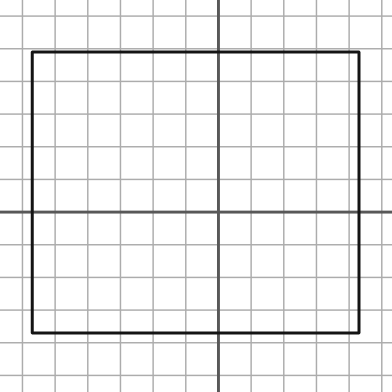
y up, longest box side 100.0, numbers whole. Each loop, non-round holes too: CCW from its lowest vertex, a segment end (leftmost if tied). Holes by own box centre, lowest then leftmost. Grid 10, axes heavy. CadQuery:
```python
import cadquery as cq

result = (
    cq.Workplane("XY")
    .moveTo(-57.0, -37.0)
    .lineTo(43.0, -37.0)
    .lineTo(43.0, 49.0)
    .lineTo(-57.0, 49.0)
    .close()
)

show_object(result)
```